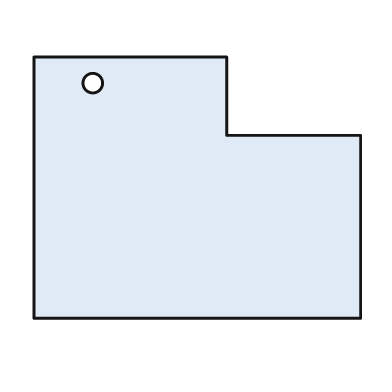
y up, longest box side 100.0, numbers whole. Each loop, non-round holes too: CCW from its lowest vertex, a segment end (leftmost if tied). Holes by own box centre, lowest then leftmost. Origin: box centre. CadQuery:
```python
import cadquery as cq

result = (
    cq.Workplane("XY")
    .moveTo(-50.0, -40.0)
    .lineTo(50.0, -40.0)
    .lineTo(50.0, 16.0)
    .lineTo(9.0, 16.0)
    .lineTo(9.0, 40.0)
    .lineTo(-50.0, 40.0)
    .close()
    .moveTo(-32.0, 32.0)
    .circle(3.0)
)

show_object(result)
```